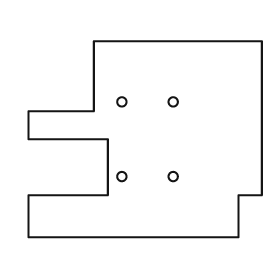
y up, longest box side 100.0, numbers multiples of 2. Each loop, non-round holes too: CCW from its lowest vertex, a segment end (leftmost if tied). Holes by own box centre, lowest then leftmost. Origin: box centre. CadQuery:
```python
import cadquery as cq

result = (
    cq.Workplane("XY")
    .moveTo(-50.0, -42.0)
    .lineTo(40.0, -42.0)
    .lineTo(40.0, -24.0)
    .lineTo(50.0, -24.0)
    .lineTo(50.0, 42.0)
    .lineTo(-22.0, 42.0)
    .lineTo(-22.0, 12.0)
    .lineTo(-50.0, 12.0)
    .lineTo(-50.0, 0.0)
    .lineTo(-16.0, 0.0)
    .lineTo(-16.0, -24.0)
    .lineTo(-50.0, -24.0)
    .close()
    .moveTo(-10.0, -16.0)
    .circle(2.0)
    .moveTo(12.0, -16.0)
    .circle(2.0)
    .moveTo(-10.0, 16.0)
    .circle(2.0)
    .moveTo(12.0, 16.0)
    .circle(2.0)
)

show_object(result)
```